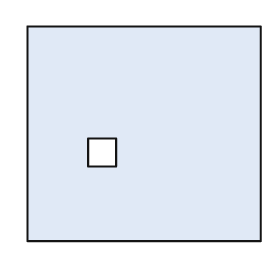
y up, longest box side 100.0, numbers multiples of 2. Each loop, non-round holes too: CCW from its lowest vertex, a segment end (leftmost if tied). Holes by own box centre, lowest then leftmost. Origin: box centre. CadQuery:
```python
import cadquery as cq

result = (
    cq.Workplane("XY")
    .moveTo(-50.0, -46.0)
    .lineTo(50.0, -46.0)
    .lineTo(50.0, 46.0)
    .lineTo(-50.0, 46.0)
    .close()
    .moveTo(-24.0, -14.0)
    .lineTo(-12.0, -14.0)
    .lineTo(-12.0, -2.0)
    .lineTo(-24.0, -2.0)
    .close()
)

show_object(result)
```